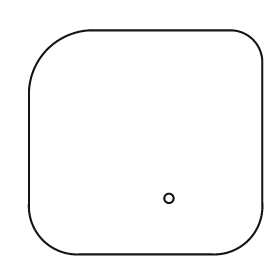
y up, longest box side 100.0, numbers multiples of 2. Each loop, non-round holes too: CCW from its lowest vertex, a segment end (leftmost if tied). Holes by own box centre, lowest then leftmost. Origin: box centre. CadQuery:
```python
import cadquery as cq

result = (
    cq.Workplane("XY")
    .moveTo(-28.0, -48.0)
    .lineTo(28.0, -48.0)
    .threePointArc((44.0, -42.0), (50.0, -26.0))
    .lineTo(50.0, 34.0)
    .threePointArc((46.0, 44.0), (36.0, 48.0))
    .lineTo(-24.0, 48.0)
    .threePointArc((-42.0, 40.0), (-50.0, 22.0))
    .lineTo(-50.0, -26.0)
    .threePointArc((-44.0, -42.0), (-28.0, -48.0))
    .close()
    .moveTo(10.0, -24.0)
    .circle(2.0)
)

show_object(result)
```